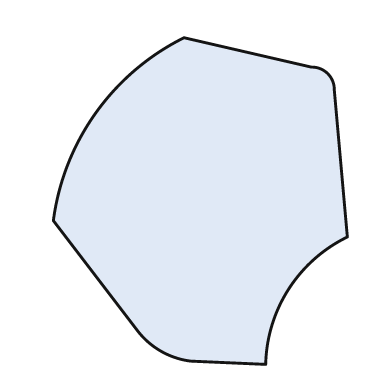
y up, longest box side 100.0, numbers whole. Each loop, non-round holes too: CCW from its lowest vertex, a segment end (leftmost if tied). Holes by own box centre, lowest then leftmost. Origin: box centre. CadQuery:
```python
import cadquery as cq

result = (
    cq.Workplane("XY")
    .moveTo(20.0, -50.0)
    .threePointArc((27.0, -27.0), (45.0, -11.0))
    .lineTo(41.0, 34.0)
    .threePointArc((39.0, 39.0), (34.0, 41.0))
    .lineTo(-5.0, 50.0)
    .threePointArc((-32.0, 27.0), (-45.0, -6.0))
    .lineTo(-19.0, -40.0)
    .threePointArc((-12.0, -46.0), (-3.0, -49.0))
    .close()
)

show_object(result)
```